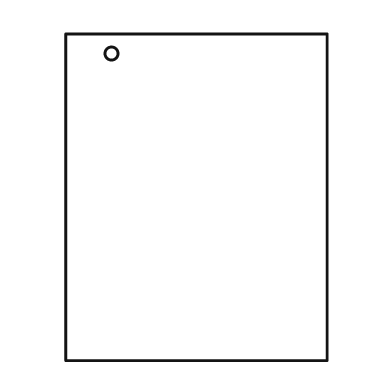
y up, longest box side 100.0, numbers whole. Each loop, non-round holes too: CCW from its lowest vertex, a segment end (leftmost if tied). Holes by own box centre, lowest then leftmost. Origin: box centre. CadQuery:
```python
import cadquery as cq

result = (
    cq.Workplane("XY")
    .moveTo(-40.0, -50.0)
    .lineTo(40.0, -50.0)
    .lineTo(40.0, 50.0)
    .lineTo(-40.0, 50.0)
    .close()
    .moveTo(-26.0, 44.0)
    .circle(2.0)
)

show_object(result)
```